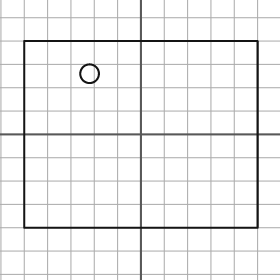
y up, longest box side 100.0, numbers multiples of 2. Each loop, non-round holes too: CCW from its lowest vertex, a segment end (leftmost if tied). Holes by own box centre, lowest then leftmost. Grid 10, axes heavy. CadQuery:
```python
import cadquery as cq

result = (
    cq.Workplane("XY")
    .moveTo(-50.0, -40.0)
    .lineTo(50.0, -40.0)
    .lineTo(50.0, 40.0)
    .lineTo(-50.0, 40.0)
    .close()
    .moveTo(-22.0, 26.0)
    .circle(4.0)
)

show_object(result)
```